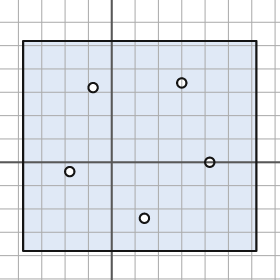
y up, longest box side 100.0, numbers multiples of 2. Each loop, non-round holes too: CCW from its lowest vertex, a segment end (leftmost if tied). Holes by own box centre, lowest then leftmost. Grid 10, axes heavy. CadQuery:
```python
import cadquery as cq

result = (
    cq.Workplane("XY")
    .moveTo(-38.0, -38.0)
    .lineTo(62.0, -38.0)
    .lineTo(62.0, 52.0)
    .lineTo(-38.0, 52.0)
    .close()
    .moveTo(14.0, -24.0)
    .circle(2.0)
    .moveTo(-18.0, -4.0)
    .circle(2.0)
    .moveTo(42.0, 0.0)
    .circle(2.0)
    .moveTo(-8.0, 32.0)
    .circle(2.0)
    .moveTo(30.0, 34.0)
    .circle(2.0)
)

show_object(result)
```